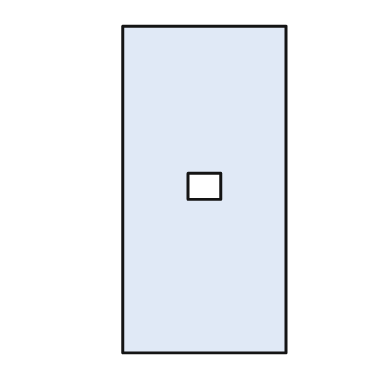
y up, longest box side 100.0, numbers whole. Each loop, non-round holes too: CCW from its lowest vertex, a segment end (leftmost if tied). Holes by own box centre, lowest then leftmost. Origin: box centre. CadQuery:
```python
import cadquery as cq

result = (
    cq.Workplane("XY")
    .moveTo(-25.0, -50.0)
    .lineTo(25.0, -50.0)
    .lineTo(25.0, 50.0)
    .lineTo(-25.0, 50.0)
    .close()
    .moveTo(-5.0, -3.0)
    .lineTo(5.0, -3.0)
    .lineTo(5.0, 5.0)
    .lineTo(-5.0, 5.0)
    .close()
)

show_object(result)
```